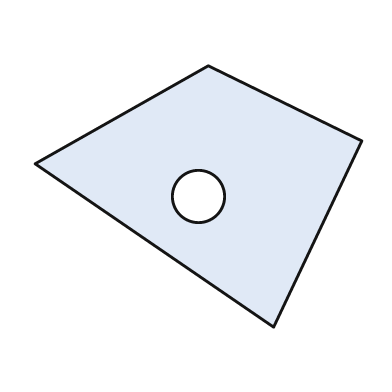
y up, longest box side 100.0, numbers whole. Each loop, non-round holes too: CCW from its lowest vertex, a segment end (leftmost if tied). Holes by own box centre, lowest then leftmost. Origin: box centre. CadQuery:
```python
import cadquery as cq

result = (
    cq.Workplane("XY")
    .moveTo(23.0, -40.0)
    .lineTo(50.0, 17.0)
    .lineTo(3.0, 40.0)
    .lineTo(-50.0, 10.0)
    .close()
    .moveTo(0.0, 0.0)
    .circle(8.0)
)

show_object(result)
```